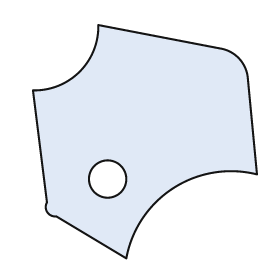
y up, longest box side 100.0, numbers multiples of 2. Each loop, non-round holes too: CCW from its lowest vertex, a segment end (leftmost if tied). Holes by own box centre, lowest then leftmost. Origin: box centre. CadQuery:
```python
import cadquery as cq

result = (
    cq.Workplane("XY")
    .moveTo(-8.0, -50.0)
    .threePointArc((12.0, -20.0), (48.0, -14.0))
    .lineTo(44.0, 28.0)
    .threePointArc((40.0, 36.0), (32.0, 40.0))
    .lineTo(-20.0, 50.0)
    .threePointArc((-28.0, 30.0), (-48.0, 22.0))
    .lineTo(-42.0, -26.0)
    .threePointArc((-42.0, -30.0), (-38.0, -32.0))
    .close()
    .moveTo(-16.0, -16.0)
    .circle(8.0)
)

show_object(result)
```